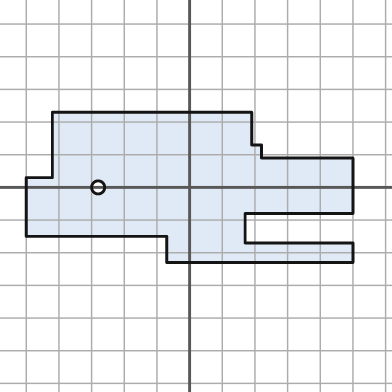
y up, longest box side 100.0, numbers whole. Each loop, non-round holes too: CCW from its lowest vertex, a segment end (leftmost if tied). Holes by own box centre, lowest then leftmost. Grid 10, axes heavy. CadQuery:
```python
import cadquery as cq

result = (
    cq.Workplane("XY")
    .moveTo(-7.0, -23.0)
    .lineTo(50.0, -23.0)
    .lineTo(50.0, -17.0)
    .lineTo(17.0, -17.0)
    .lineTo(17.0, -8.0)
    .lineTo(50.0, -8.0)
    .lineTo(50.0, 9.0)
    .lineTo(22.0, 9.0)
    .lineTo(22.0, 13.0)
    .lineTo(19.0, 13.0)
    .lineTo(19.0, 23.0)
    .lineTo(-42.0, 23.0)
    .lineTo(-42.0, 3.0)
    .lineTo(-50.0, 3.0)
    .lineTo(-50.0, -15.0)
    .lineTo(-7.0, -15.0)
    .close()
    .moveTo(-28.0, 0.0)
    .circle(2.0)
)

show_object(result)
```